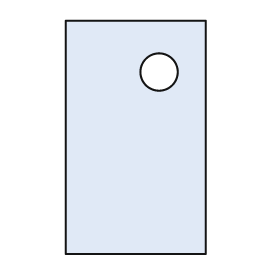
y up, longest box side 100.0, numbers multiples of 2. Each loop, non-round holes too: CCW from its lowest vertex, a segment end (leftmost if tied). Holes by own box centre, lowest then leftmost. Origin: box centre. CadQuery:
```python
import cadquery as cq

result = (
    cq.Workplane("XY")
    .moveTo(-30.0, -50.0)
    .lineTo(30.0, -50.0)
    .lineTo(30.0, 50.0)
    .lineTo(-30.0, 50.0)
    .close()
    .moveTo(10.0, 28.0)
    .circle(8.0)
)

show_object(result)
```